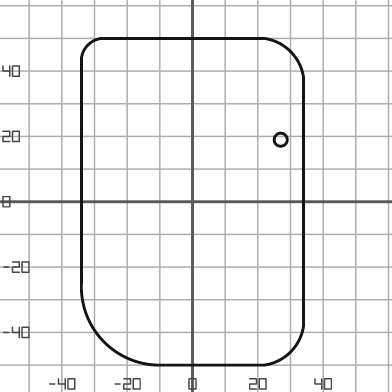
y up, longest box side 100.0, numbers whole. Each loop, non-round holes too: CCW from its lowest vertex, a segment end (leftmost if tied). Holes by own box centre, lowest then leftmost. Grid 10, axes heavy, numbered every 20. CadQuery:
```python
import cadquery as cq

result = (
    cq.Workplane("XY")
    .moveTo(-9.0, -50.0)
    .lineTo(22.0, -50.0)
    .threePointArc((30.0, -46.0), (34.0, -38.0))
    .lineTo(34.0, 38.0)
    .threePointArc((30.0, 46.0), (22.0, 50.0))
    .lineTo(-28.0, 50.0)
    .threePointArc((-32.0, 48.0), (-34.0, 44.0))
    .lineTo(-34.0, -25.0)
    .threePointArc((-27.0, -43.0), (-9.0, -50.0))
    .close()
    .moveTo(27.0, 19.0)
    .circle(2.0)
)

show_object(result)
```